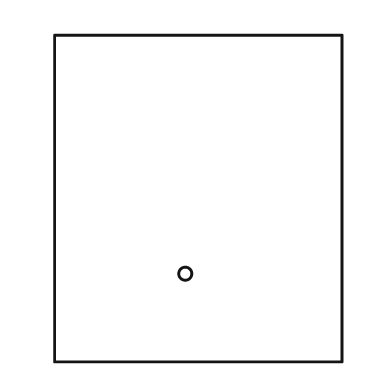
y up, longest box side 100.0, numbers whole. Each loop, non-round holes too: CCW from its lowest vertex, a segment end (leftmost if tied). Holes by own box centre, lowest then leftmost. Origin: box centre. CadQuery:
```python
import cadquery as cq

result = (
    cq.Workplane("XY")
    .moveTo(-44.0, -50.0)
    .lineTo(44.0, -50.0)
    .lineTo(44.0, 50.0)
    .lineTo(-44.0, 50.0)
    .close()
    .moveTo(-4.0, -23.0)
    .circle(2.0)
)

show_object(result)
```